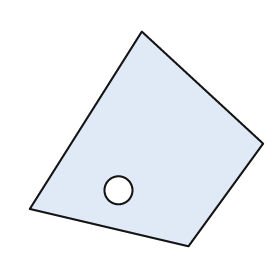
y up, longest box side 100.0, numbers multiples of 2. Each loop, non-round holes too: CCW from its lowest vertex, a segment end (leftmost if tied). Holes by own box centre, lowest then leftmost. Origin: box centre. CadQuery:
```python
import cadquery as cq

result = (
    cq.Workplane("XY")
    .moveTo(18.0, -46.0)
    .lineTo(50.0, -2.0)
    .lineTo(-2.0, 46.0)
    .lineTo(-50.0, -30.0)
    .close()
    .moveTo(-12.0, -22.0)
    .circle(6.0)
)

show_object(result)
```